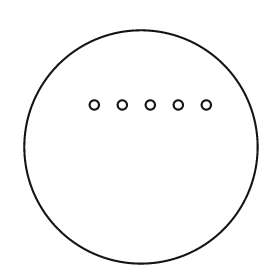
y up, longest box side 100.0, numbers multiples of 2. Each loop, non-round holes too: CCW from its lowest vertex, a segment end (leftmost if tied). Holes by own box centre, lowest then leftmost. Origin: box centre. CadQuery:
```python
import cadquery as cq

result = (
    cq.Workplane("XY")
    .moveTo(0.0, 0.0)
    .circle(50.0)
    .moveTo(-20.0, 18.0)
    .circle(2.0)
    .moveTo(-8.0, 18.0)
    .circle(2.0)
    .moveTo(4.0, 18.0)
    .circle(2.0)
    .moveTo(16.0, 18.0)
    .circle(2.0)
    .moveTo(28.0, 18.0)
    .circle(2.0)
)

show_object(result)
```